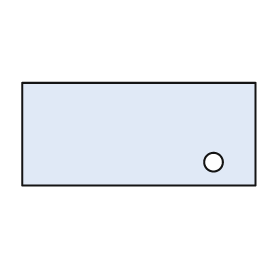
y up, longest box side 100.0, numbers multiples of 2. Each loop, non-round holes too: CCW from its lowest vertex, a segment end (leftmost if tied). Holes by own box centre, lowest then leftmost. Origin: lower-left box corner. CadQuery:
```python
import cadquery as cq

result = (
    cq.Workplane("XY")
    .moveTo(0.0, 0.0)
    .lineTo(100.0, 0.0)
    .lineTo(100.0, 44.0)
    .lineTo(0.0, 44.0)
    .close()
    .moveTo(82.0, 10.0)
    .circle(4.0)
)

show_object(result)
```